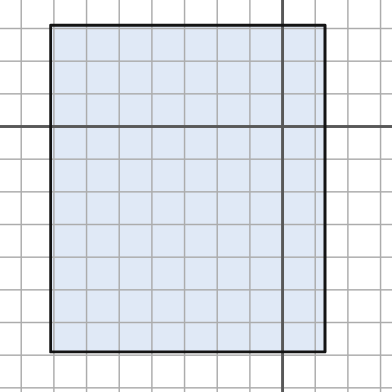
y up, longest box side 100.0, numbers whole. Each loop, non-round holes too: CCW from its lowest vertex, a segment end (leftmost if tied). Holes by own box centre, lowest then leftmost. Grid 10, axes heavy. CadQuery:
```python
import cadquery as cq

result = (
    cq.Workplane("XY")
    .moveTo(-71.0, -69.0)
    .lineTo(13.0, -69.0)
    .lineTo(13.0, 31.0)
    .lineTo(-71.0, 31.0)
    .close()
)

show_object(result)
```